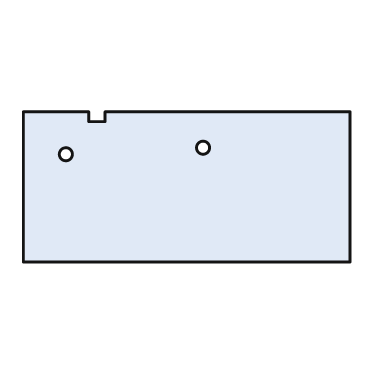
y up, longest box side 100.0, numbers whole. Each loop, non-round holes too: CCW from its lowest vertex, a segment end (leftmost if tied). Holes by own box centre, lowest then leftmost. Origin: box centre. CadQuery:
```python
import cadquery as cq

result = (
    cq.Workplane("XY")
    .moveTo(-50.0, -23.0)
    .lineTo(50.0, -23.0)
    .lineTo(50.0, 23.0)
    .lineTo(-25.0, 23.0)
    .lineTo(-25.0, 20.0)
    .lineTo(-30.0, 20.0)
    .lineTo(-30.0, 23.0)
    .lineTo(-50.0, 23.0)
    .close()
    .moveTo(-37.0, 10.0)
    .circle(2.0)
    .moveTo(5.0, 12.0)
    .circle(2.0)
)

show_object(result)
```